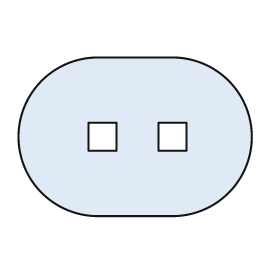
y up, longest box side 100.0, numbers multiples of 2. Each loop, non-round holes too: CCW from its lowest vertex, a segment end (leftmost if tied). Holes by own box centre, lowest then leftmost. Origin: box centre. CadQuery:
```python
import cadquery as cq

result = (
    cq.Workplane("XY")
    .moveTo(-16.0, -34.0)
    .lineTo(16.0, -34.0)
    .threePointArc((50.0, 0.0), (16.0, 34.0))
    .lineTo(-16.0, 34.0)
    .threePointArc((-50.0, 0.0), (-16.0, -34.0))
    .close()
    .moveTo(-20.0, -6.0)
    .lineTo(-8.0, -6.0)
    .lineTo(-8.0, 6.0)
    .lineTo(-20.0, 6.0)
    .close()
    .moveTo(10.0, -6.0)
    .lineTo(22.0, -6.0)
    .lineTo(22.0, 6.0)
    .lineTo(10.0, 6.0)
    .close()
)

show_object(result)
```